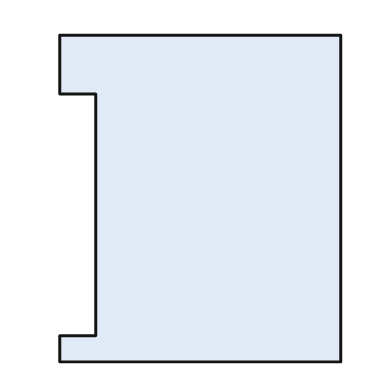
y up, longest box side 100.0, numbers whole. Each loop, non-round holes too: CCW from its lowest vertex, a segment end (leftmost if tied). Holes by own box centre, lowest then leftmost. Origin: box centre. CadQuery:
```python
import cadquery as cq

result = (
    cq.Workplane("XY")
    .moveTo(-43.0, -50.0)
    .lineTo(43.0, -50.0)
    .lineTo(43.0, 50.0)
    .lineTo(-43.0, 50.0)
    .lineTo(-43.0, 32.0)
    .lineTo(-32.0, 32.0)
    .lineTo(-32.0, -42.0)
    .lineTo(-43.0, -42.0)
    .close()
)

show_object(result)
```